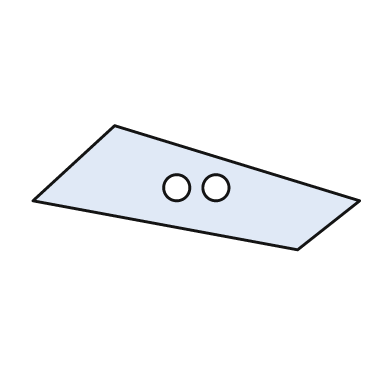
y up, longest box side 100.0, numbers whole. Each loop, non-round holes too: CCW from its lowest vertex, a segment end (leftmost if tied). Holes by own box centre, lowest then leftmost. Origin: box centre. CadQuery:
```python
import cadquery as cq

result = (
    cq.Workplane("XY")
    .moveTo(31.0, -19.0)
    .lineTo(50.0, -4.0)
    .lineTo(-25.0, 19.0)
    .lineTo(-50.0, -4.0)
    .close()
    .moveTo(-6.0, 0.0)
    .circle(4.0)
    .moveTo(6.0, 0.0)
    .circle(4.0)
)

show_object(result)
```